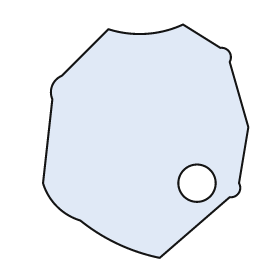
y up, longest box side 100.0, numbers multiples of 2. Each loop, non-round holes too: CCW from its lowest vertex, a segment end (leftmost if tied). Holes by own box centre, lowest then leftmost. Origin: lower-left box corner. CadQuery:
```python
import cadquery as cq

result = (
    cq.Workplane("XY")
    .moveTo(50.0, 0.0)
    .lineTo(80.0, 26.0)
    .threePointArc((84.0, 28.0), (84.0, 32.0))
    .lineTo(88.0, 56.0)
    .lineTo(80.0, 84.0)
    .threePointArc((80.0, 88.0), (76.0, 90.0))
    .lineTo(60.0, 100.0)
    .threePointArc((44.0, 96.0), (28.0, 98.0))
    .lineTo(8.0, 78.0)
    .threePointArc((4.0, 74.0), (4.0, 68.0))
    .lineTo(0.0, 32.0)
    .threePointArc((6.0, 22.0), (16.0, 16.0))
    .threePointArc((32.0, 6.0), (50.0, 0.0))
    .close()
    .moveTo(66.0, 32.0)
    .circle(8.0)
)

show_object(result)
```